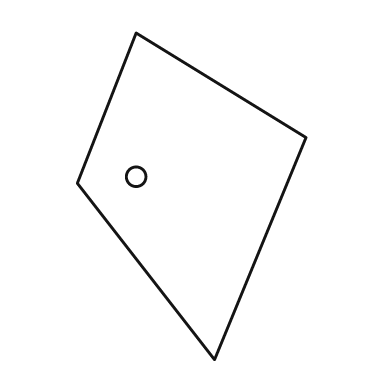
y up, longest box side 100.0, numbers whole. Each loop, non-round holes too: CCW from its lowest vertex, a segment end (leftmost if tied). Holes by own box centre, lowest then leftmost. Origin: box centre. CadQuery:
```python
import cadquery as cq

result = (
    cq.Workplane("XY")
    .moveTo(7.0, -50.0)
    .lineTo(35.0, 18.0)
    .lineTo(-17.0, 50.0)
    .lineTo(-35.0, 4.0)
    .close()
    .moveTo(-17.0, 6.0)
    .circle(3.0)
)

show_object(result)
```